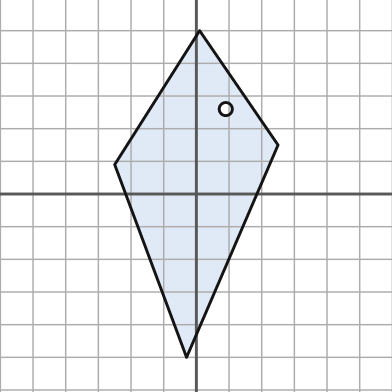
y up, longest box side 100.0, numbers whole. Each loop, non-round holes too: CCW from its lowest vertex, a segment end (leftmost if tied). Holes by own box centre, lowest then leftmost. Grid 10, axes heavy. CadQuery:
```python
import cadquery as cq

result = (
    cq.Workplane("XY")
    .moveTo(-3.0, -50.0)
    .lineTo(25.0, 15.0)
    .lineTo(1.0, 50.0)
    .lineTo(-25.0, 9.0)
    .close()
    .moveTo(9.0, 26.0)
    .circle(2.0)
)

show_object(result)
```